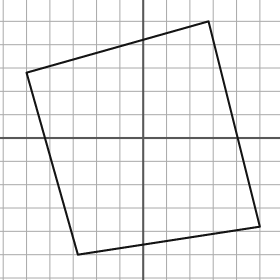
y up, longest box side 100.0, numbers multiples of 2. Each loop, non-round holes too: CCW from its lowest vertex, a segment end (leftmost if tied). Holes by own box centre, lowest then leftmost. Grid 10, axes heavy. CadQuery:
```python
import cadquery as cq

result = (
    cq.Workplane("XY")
    .moveTo(-28.0, -50.0)
    .lineTo(50.0, -38.0)
    .lineTo(28.0, 50.0)
    .lineTo(-50.0, 28.0)
    .close()
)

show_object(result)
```